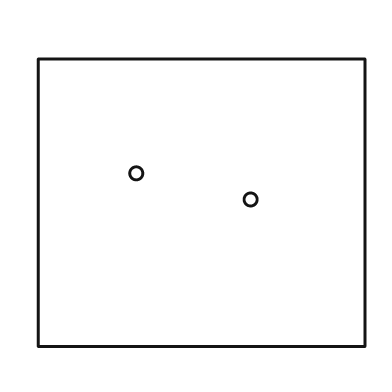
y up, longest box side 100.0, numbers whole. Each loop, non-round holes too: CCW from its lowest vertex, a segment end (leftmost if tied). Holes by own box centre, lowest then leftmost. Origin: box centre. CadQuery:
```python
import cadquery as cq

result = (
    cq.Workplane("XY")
    .moveTo(-50.0, -44.0)
    .lineTo(50.0, -44.0)
    .lineTo(50.0, 44.0)
    .lineTo(-50.0, 44.0)
    .close()
    .moveTo(15.0, 1.0)
    .circle(2.0)
    .moveTo(-20.0, 9.0)
    .circle(2.0)
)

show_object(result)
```